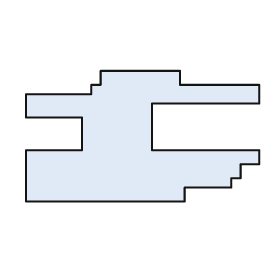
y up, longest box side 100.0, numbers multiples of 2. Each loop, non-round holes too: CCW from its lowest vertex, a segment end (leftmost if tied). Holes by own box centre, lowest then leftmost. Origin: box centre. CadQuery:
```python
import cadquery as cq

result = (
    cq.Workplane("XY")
    .moveTo(-50.0, -28.0)
    .lineTo(18.0, -28.0)
    .lineTo(18.0, -22.0)
    .lineTo(38.0, -22.0)
    .lineTo(38.0, -18.0)
    .lineTo(42.0, -18.0)
    .lineTo(42.0, -12.0)
    .lineTo(50.0, -12.0)
    .lineTo(50.0, -6.0)
    .lineTo(4.0, -6.0)
    .lineTo(4.0, 14.0)
    .lineTo(50.0, 14.0)
    .lineTo(50.0, 22.0)
    .lineTo(16.0, 22.0)
    .lineTo(16.0, 28.0)
    .lineTo(-18.0, 28.0)
    .lineTo(-18.0, 22.0)
    .lineTo(-22.0, 22.0)
    .lineTo(-22.0, 18.0)
    .lineTo(-50.0, 18.0)
    .lineTo(-50.0, 8.0)
    .lineTo(-26.0, 8.0)
    .lineTo(-26.0, -6.0)
    .lineTo(-50.0, -6.0)
    .close()
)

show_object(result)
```